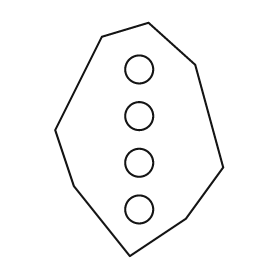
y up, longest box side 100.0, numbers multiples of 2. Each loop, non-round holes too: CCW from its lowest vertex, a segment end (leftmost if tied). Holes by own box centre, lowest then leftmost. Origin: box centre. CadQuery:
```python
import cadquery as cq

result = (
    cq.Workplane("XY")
    .moveTo(-4.0, -50.0)
    .lineTo(20.0, -34.0)
    .lineTo(36.0, -12.0)
    .lineTo(24.0, 32.0)
    .lineTo(4.0, 50.0)
    .lineTo(-16.0, 44.0)
    .lineTo(-36.0, 4.0)
    .lineTo(-28.0, -20.0)
    .close()
    .moveTo(0.0, -30.0)
    .circle(6.0)
    .moveTo(0.0, -10.0)
    .circle(6.0)
    .moveTo(0.0, 10.0)
    .circle(6.0)
    .moveTo(0.0, 30.0)
    .circle(6.0)
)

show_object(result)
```